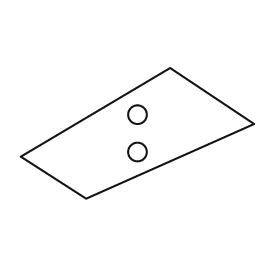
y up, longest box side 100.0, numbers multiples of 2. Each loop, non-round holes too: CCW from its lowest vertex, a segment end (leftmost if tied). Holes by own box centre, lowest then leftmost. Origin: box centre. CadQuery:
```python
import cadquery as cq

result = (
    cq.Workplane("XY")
    .moveTo(-22.0, -28.0)
    .lineTo(50.0, 4.0)
    .lineTo(14.0, 28.0)
    .lineTo(-50.0, -10.0)
    .close()
    .moveTo(0.0, -8.0)
    .circle(4.0)
    .moveTo(0.0, 8.0)
    .circle(4.0)
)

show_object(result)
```